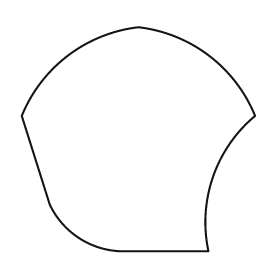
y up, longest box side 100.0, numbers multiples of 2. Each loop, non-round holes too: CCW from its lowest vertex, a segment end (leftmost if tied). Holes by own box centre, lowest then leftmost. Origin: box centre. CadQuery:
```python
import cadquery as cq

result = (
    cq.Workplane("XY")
    .moveTo(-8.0, -48.0)
    .lineTo(30.0, -48.0)
    .threePointArc((32.0, -16.0), (50.0, 10.0))
    .threePointArc((30.0, 36.0), (0.0, 48.0))
    .threePointArc((-30.0, 36.0), (-50.0, 10.0))
    .lineTo(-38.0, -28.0)
    .threePointArc((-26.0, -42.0), (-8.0, -48.0))
    .close()
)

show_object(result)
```